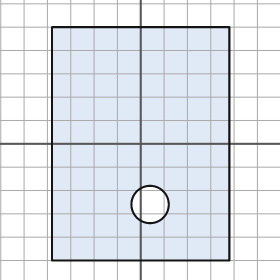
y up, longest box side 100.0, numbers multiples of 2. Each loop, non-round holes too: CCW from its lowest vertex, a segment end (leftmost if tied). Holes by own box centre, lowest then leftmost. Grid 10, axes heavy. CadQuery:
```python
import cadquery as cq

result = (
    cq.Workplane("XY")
    .moveTo(-38.0, -50.0)
    .lineTo(38.0, -50.0)
    .lineTo(38.0, 50.0)
    .lineTo(-38.0, 50.0)
    .close()
    .moveTo(4.0, -26.0)
    .circle(8.0)
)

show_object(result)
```